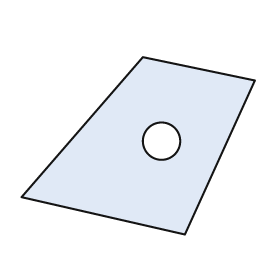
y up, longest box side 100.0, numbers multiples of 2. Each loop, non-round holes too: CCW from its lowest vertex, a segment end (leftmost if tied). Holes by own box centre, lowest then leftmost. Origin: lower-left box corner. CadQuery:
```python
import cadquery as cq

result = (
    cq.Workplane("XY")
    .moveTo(70.0, 0.0)
    .lineTo(100.0, 66.0)
    .lineTo(52.0, 76.0)
    .lineTo(0.0, 16.0)
    .close()
    .moveTo(60.0, 40.0)
    .circle(8.0)
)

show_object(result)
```